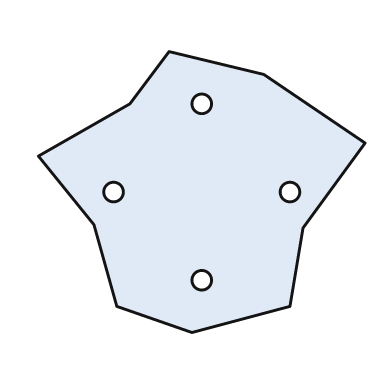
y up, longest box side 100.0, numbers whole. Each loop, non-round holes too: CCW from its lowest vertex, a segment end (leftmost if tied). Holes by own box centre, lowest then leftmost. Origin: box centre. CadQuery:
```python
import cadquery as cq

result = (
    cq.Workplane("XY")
    .moveTo(-3.0, -43.0)
    .lineTo(27.0, -35.0)
    .lineTo(31.0, -11.0)
    .lineTo(50.0, 15.0)
    .lineTo(19.0, 36.0)
    .lineTo(-10.0, 43.0)
    .lineTo(-22.0, 27.0)
    .lineTo(-50.0, 11.0)
    .lineTo(-33.0, -10.0)
    .lineTo(-26.0, -35.0)
    .close()
    .moveTo(0.0, -27.0)
    .circle(3.0)
    .moveTo(-27.0, 0.0)
    .circle(3.0)
    .moveTo(27.0, 0.0)
    .circle(3.0)
    .moveTo(0.0, 27.0)
    .circle(3.0)
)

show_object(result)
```